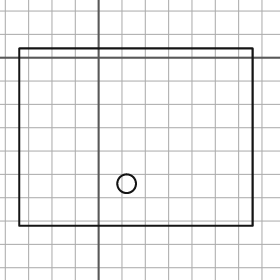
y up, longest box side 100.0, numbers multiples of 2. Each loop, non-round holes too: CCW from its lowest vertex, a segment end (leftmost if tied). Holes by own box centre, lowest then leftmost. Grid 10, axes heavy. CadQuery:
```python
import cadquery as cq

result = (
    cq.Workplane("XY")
    .moveTo(-34.0, -72.0)
    .lineTo(66.0, -72.0)
    .lineTo(66.0, 4.0)
    .lineTo(-34.0, 4.0)
    .close()
    .moveTo(12.0, -54.0)
    .circle(4.0)
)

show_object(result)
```